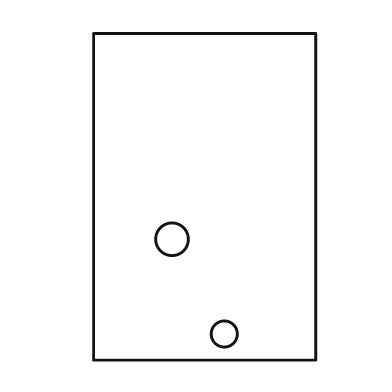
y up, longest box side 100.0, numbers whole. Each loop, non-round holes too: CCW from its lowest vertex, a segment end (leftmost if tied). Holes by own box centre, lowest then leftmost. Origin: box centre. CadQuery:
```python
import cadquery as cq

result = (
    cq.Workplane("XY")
    .moveTo(-34.0, -50.0)
    .lineTo(34.0, -50.0)
    .lineTo(34.0, 50.0)
    .lineTo(-34.0, 50.0)
    .close()
    .moveTo(6.0, -42.0)
    .circle(4.0)
    .moveTo(-10.0, -13.0)
    .circle(5.0)
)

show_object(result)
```